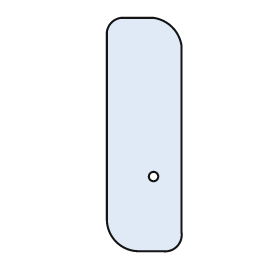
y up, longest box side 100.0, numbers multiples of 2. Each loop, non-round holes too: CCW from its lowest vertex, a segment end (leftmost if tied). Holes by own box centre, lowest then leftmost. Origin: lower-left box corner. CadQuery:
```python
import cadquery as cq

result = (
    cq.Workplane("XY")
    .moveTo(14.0, 0.0)
    .lineTo(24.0, 0.0)
    .threePointArc((30.0, 2.0), (32.0, 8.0))
    .lineTo(32.0, 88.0)
    .threePointArc((28.0, 96.0), (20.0, 100.0))
    .lineTo(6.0, 100.0)
    .threePointArc((2.0, 98.0), (0.0, 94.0))
    .lineTo(0.0, 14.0)
    .threePointArc((4.0, 4.0), (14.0, 0.0))
    .close()
    .moveTo(20.0, 32.0)
    .circle(2.0)
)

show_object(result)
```